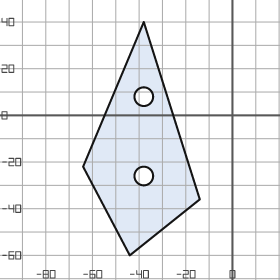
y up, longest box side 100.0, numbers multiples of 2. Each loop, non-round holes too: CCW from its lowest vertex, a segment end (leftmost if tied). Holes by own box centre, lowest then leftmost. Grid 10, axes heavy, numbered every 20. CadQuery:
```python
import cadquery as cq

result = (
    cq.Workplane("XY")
    .moveTo(-44.0, -60.0)
    .lineTo(-14.0, -36.0)
    .lineTo(-38.0, 40.0)
    .lineTo(-64.0, -22.0)
    .close()
    .moveTo(-38.0, -26.0)
    .circle(4.0)
    .moveTo(-38.0, 8.0)
    .circle(4.0)
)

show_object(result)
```